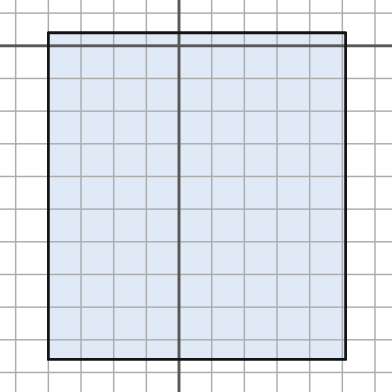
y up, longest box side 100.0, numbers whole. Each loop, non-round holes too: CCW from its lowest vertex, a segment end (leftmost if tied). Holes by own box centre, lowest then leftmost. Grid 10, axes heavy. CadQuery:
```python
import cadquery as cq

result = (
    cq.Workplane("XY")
    .moveTo(-40.0, -96.0)
    .lineTo(51.0, -96.0)
    .lineTo(51.0, 4.0)
    .lineTo(-40.0, 4.0)
    .close()
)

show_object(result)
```